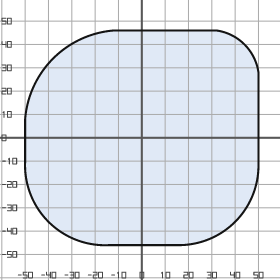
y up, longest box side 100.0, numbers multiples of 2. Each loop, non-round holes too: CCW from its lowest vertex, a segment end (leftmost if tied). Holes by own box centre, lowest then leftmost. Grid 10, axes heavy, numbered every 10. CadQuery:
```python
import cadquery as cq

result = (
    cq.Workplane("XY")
    .moveTo(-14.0, -46.0)
    .lineTo(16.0, -46.0)
    .threePointArc((40.0, -36.0), (50.0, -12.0))
    .lineTo(50.0, 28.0)
    .threePointArc((44.0, 40.0), (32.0, 46.0))
    .lineTo(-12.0, 46.0)
    .threePointArc((-38.0, 34.0), (-50.0, 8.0))
    .lineTo(-50.0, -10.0)
    .threePointArc((-40.0, -36.0), (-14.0, -46.0))
    .close()
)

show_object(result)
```